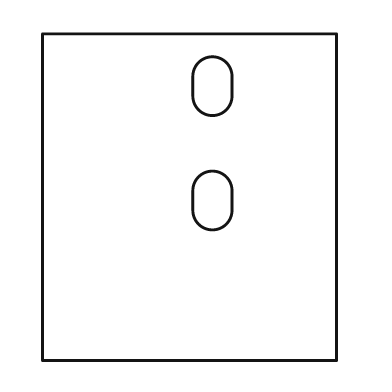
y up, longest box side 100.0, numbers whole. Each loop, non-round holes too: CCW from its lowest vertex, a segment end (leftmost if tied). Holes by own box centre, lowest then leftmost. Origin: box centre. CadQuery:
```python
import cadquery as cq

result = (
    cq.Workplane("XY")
    .moveTo(-45.0, -50.0)
    .lineTo(45.0, -50.0)
    .lineTo(45.0, 50.0)
    .lineTo(-45.0, 50.0)
    .close()
    .moveTo(1.0, -4.0)
    .threePointArc((7.0, -10.0), (13.0, -4.0))
    .lineTo(13.0, 2.0)
    .threePointArc((7.0, 8.0), (1.0, 2.0))
    .close()
    .moveTo(1.0, 31.0)
    .threePointArc((7.0, 25.0), (13.0, 31.0))
    .lineTo(13.0, 37.0)
    .threePointArc((7.0, 43.0), (1.0, 37.0))
    .close()
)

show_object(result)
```